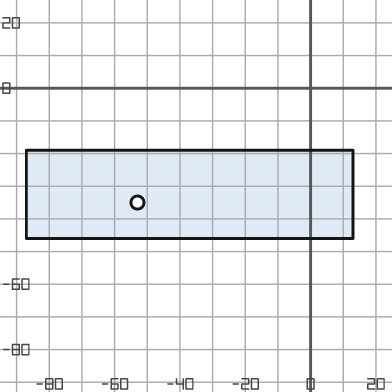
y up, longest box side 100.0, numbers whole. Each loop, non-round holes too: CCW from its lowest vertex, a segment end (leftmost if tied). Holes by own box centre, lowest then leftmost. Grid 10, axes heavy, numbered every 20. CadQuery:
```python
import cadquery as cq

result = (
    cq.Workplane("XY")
    .moveTo(-87.0, -46.0)
    .lineTo(13.0, -46.0)
    .lineTo(13.0, -19.0)
    .lineTo(-87.0, -19.0)
    .close()
    .moveTo(-53.0, -35.0)
    .circle(2.0)
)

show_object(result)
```